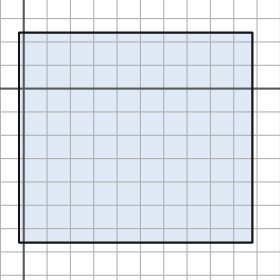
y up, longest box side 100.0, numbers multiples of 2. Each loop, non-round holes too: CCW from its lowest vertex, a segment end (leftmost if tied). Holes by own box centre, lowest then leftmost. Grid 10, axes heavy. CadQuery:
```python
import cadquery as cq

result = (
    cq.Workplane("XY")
    .moveTo(-2.0, -66.0)
    .lineTo(98.0, -66.0)
    .lineTo(98.0, 24.0)
    .lineTo(-2.0, 24.0)
    .close()
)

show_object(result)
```